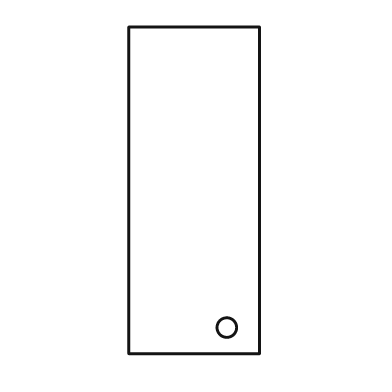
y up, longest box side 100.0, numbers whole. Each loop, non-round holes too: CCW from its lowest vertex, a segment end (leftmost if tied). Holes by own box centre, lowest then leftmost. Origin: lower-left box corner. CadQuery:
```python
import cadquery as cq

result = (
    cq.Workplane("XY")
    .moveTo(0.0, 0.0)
    .lineTo(40.0, 0.0)
    .lineTo(40.0, 100.0)
    .lineTo(0.0, 100.0)
    .close()
    .moveTo(30.0, 8.0)
    .circle(3.0)
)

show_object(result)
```